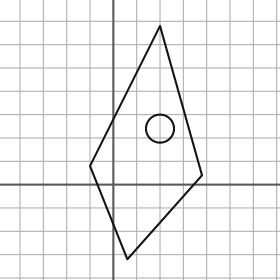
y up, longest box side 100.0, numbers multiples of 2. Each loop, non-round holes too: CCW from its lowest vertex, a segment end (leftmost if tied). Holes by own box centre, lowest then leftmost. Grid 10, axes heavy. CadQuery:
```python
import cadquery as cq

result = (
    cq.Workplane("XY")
    .moveTo(6.0, -32.0)
    .lineTo(38.0, 4.0)
    .lineTo(20.0, 68.0)
    .lineTo(-10.0, 8.0)
    .close()
    .moveTo(20.0, 24.0)
    .circle(6.0)
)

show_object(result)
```